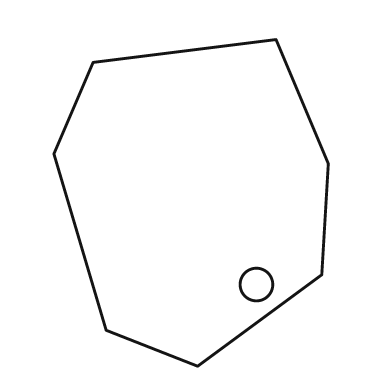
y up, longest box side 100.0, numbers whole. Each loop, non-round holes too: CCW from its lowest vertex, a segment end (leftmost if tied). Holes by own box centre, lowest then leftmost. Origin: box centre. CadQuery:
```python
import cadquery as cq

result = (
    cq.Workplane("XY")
    .moveTo(2.0, -50.0)
    .lineTo(40.0, -22.0)
    .lineTo(42.0, 12.0)
    .lineTo(26.0, 50.0)
    .lineTo(-30.0, 43.0)
    .lineTo(-42.0, 15.0)
    .lineTo(-26.0, -39.0)
    .close()
    .moveTo(20.0, -25.0)
    .circle(5.0)
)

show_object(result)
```